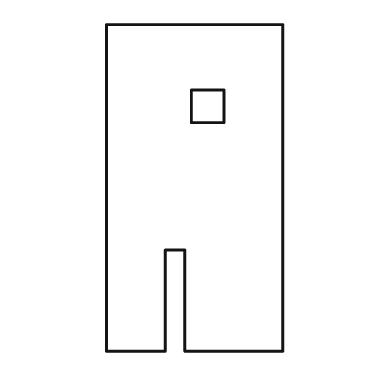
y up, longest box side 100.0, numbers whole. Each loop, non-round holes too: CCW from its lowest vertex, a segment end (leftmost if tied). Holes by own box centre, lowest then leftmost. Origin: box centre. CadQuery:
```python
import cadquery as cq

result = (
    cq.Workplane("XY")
    .moveTo(-27.0, -50.0)
    .lineTo(-9.0, -50.0)
    .lineTo(-9.0, -19.0)
    .lineTo(-3.0, -19.0)
    .lineTo(-3.0, -50.0)
    .lineTo(27.0, -50.0)
    .lineTo(27.0, 50.0)
    .lineTo(-27.0, 50.0)
    .close()
    .moveTo(-1.0, 20.0)
    .lineTo(9.0, 20.0)
    .lineTo(9.0, 30.0)
    .lineTo(-1.0, 30.0)
    .close()
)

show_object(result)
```